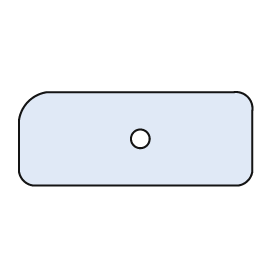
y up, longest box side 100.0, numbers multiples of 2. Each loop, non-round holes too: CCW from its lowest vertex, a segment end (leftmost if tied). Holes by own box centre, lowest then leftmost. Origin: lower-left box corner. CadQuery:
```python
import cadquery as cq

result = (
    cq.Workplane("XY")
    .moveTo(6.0, 0.0)
    .lineTo(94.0, 0.0)
    .threePointArc((98.0, 2.0), (100.0, 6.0))
    .lineTo(100.0, 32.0)
    .threePointArc((98.0, 38.0), (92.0, 40.0))
    .lineTo(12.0, 40.0)
    .threePointArc((4.0, 36.0), (0.0, 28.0))
    .lineTo(0.0, 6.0)
    .threePointArc((2.0, 2.0), (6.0, 0.0))
    .close()
    .moveTo(52.0, 20.0)
    .circle(4.0)
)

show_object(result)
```